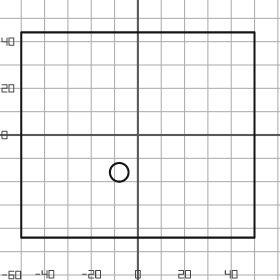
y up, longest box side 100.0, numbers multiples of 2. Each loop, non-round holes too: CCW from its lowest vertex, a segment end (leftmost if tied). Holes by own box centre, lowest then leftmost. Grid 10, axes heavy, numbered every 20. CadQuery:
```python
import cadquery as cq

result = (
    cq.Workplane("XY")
    .moveTo(-50.0, -44.0)
    .lineTo(50.0, -44.0)
    .lineTo(50.0, 44.0)
    .lineTo(-50.0, 44.0)
    .close()
    .moveTo(-8.0, -16.0)
    .circle(4.0)
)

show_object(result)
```